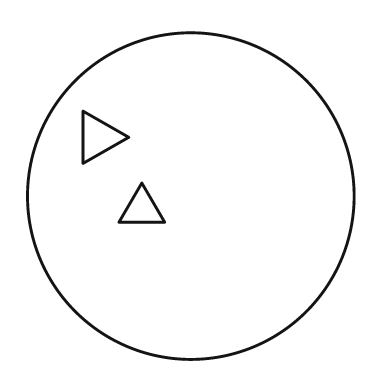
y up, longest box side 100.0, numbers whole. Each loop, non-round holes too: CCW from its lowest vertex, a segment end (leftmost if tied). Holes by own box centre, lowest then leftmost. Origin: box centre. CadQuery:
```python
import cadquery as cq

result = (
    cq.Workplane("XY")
    .moveTo(0.0, 0.0)
    .circle(50.0)
    .moveTo(-22.0, -8.0)
    .lineTo(-8.0, -8.0)
    .lineTo(-15.0, 4.0)
    .close()
    .moveTo(-33.0, 10.0)
    .lineTo(-19.0, 18.0)
    .lineTo(-33.0, 26.0)
    .close()
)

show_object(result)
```